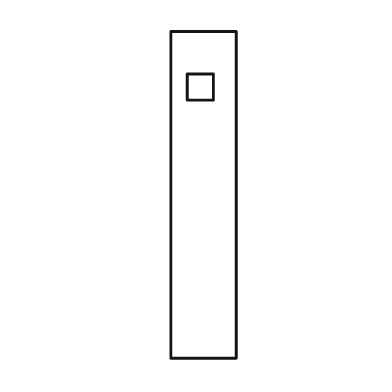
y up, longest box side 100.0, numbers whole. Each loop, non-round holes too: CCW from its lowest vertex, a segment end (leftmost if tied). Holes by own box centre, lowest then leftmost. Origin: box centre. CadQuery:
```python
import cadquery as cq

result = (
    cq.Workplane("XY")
    .moveTo(-10.0, -50.0)
    .lineTo(10.0, -50.0)
    .lineTo(10.0, 50.0)
    .lineTo(-10.0, 50.0)
    .close()
    .moveTo(-5.0, 29.0)
    .lineTo(3.0, 29.0)
    .lineTo(3.0, 37.0)
    .lineTo(-5.0, 37.0)
    .close()
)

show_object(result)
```